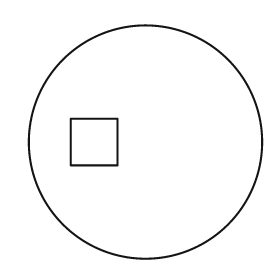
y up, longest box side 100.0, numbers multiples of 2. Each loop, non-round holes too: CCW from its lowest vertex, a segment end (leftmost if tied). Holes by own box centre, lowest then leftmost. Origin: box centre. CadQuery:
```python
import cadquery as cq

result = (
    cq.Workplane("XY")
    .moveTo(0.0, 0.0)
    .circle(50.0)
    .moveTo(-32.0, -10.0)
    .lineTo(-12.0, -10.0)
    .lineTo(-12.0, 10.0)
    .lineTo(-32.0, 10.0)
    .close()
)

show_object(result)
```